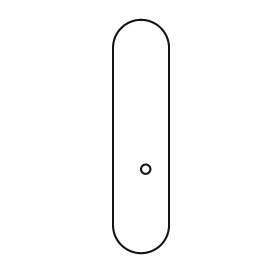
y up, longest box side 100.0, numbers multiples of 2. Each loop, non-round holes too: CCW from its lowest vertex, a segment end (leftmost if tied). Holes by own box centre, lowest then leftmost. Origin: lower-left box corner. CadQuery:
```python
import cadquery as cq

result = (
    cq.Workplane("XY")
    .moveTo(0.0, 12.0)
    .threePointArc((12.0, 0.0), (24.0, 12.0))
    .lineTo(24.0, 88.0)
    .threePointArc((12.0, 100.0), (0.0, 88.0))
    .close()
    .moveTo(14.0, 36.0)
    .circle(2.0)
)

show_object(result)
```